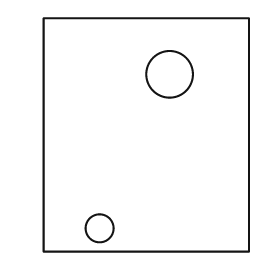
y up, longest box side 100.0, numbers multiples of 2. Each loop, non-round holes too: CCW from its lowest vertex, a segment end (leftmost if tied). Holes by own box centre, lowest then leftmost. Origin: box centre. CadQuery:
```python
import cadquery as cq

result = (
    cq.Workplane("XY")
    .moveTo(-44.0, -50.0)
    .lineTo(44.0, -50.0)
    .lineTo(44.0, 50.0)
    .lineTo(-44.0, 50.0)
    .close()
    .moveTo(-20.0, -40.0)
    .circle(6.0)
    .moveTo(10.0, 26.0)
    .circle(10.0)
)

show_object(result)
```